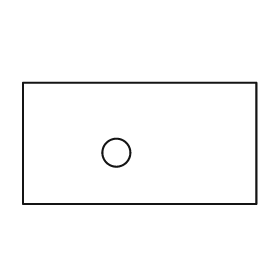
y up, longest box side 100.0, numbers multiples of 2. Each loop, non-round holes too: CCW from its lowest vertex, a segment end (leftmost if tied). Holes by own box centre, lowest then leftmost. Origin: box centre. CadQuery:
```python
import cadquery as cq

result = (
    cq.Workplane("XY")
    .moveTo(-50.0, -26.0)
    .lineTo(50.0, -26.0)
    .lineTo(50.0, 26.0)
    .lineTo(-50.0, 26.0)
    .close()
    .moveTo(-10.0, -4.0)
    .circle(6.0)
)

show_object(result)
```